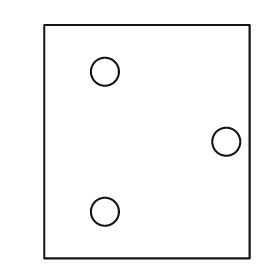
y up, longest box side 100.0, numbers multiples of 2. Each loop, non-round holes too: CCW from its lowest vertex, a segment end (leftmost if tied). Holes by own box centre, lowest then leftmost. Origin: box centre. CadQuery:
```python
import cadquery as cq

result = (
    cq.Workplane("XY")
    .moveTo(-44.0, -50.0)
    .lineTo(44.0, -50.0)
    .lineTo(44.0, 50.0)
    .lineTo(-44.0, 50.0)
    .close()
    .moveTo(-18.0, -30.0)
    .circle(6.0)
    .moveTo(34.0, 0.0)
    .circle(6.0)
    .moveTo(-18.0, 30.0)
    .circle(6.0)
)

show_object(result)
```